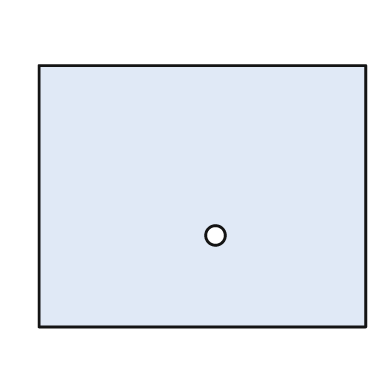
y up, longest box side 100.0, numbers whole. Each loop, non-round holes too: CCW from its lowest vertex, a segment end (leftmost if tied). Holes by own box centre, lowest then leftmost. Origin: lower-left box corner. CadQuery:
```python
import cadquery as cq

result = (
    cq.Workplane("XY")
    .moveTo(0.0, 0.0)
    .lineTo(100.0, 0.0)
    .lineTo(100.0, 80.0)
    .lineTo(0.0, 80.0)
    .close()
    .moveTo(54.0, 28.0)
    .circle(3.0)
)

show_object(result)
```